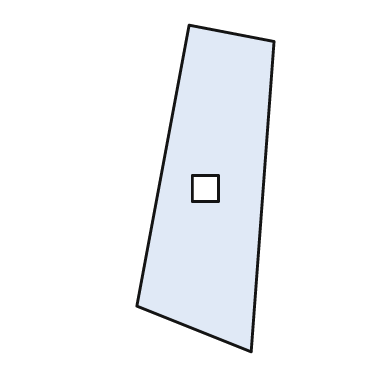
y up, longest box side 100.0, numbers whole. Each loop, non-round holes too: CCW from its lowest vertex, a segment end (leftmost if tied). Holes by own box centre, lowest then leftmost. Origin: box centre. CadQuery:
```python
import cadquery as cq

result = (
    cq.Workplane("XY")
    .moveTo(14.0, -50.0)
    .lineTo(21.0, 45.0)
    .lineTo(-5.0, 50.0)
    .lineTo(-21.0, -36.0)
    .close()
    .moveTo(-4.0, -4.0)
    .lineTo(4.0, -4.0)
    .lineTo(4.0, 4.0)
    .lineTo(-4.0, 4.0)
    .close()
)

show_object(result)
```